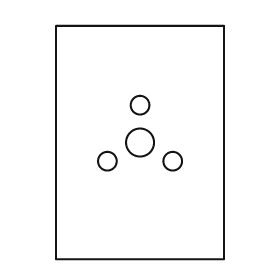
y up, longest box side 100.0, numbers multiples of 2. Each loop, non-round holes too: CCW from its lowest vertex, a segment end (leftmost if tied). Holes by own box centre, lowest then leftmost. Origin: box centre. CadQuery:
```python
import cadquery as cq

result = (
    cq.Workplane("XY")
    .moveTo(-36.0, -50.0)
    .lineTo(36.0, -50.0)
    .lineTo(36.0, 50.0)
    .lineTo(-36.0, 50.0)
    .close()
    .moveTo(-14.0, -8.0)
    .circle(4.0)
    .moveTo(14.0, -8.0)
    .circle(4.0)
    .moveTo(0.0, 0.0)
    .circle(6.0)
    .moveTo(0.0, 16.0)
    .circle(4.0)
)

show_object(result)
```